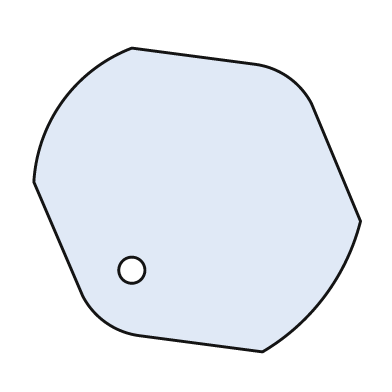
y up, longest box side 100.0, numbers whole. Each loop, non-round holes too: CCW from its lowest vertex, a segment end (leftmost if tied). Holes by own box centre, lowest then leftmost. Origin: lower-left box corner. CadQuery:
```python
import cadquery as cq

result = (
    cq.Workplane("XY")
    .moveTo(70.0, 0.0)
    .threePointArc((89.0, 17.0), (100.0, 40.0))
    .lineTo(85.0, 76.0)
    .threePointArc((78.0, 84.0), (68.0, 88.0))
    .lineTo(30.0, 93.0)
    .threePointArc((9.0, 77.0), (0.0, 52.0))
    .lineTo(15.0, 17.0)
    .threePointArc((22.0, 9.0), (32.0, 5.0))
    .close()
    .moveTo(30.0, 25.0)
    .circle(4.0)
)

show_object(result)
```